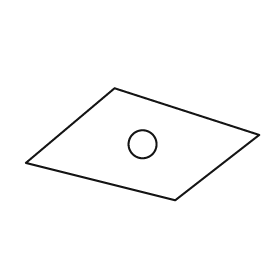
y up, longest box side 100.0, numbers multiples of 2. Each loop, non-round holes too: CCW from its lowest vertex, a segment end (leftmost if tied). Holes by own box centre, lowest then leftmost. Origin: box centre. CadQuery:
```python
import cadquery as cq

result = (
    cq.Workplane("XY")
    .moveTo(14.0, -24.0)
    .lineTo(50.0, 4.0)
    .lineTo(-12.0, 24.0)
    .lineTo(-50.0, -8.0)
    .close()
    .moveTo(0.0, 0.0)
    .circle(6.0)
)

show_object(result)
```